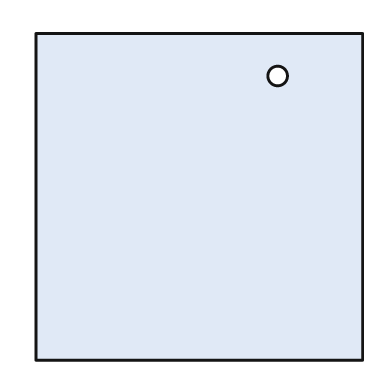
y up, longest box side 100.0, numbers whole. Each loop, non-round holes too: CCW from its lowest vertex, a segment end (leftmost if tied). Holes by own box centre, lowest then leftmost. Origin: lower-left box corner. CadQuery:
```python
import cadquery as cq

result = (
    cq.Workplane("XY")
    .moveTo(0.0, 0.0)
    .lineTo(100.0, 0.0)
    .lineTo(100.0, 100.0)
    .lineTo(0.0, 100.0)
    .close()
    .moveTo(74.0, 87.0)
    .circle(3.0)
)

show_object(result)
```